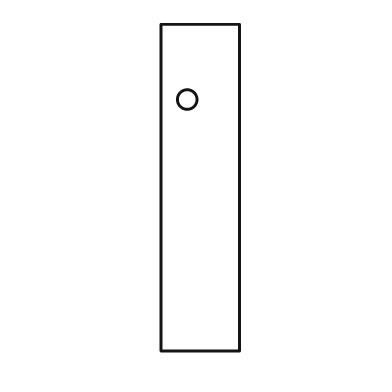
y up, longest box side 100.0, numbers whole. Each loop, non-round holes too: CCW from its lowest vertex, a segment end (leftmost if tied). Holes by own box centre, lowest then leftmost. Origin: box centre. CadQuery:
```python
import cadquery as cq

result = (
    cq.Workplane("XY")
    .moveTo(-12.0, -50.0)
    .lineTo(12.0, -50.0)
    .lineTo(12.0, 50.0)
    .lineTo(-12.0, 50.0)
    .close()
    .moveTo(-4.0, 27.0)
    .circle(3.0)
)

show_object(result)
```